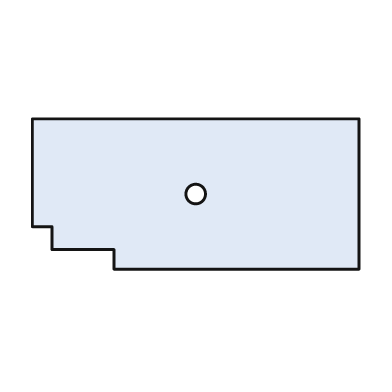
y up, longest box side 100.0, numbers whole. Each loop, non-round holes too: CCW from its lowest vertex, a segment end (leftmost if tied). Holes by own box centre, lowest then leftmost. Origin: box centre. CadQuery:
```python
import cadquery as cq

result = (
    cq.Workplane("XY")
    .moveTo(-25.0, -23.0)
    .lineTo(50.0, -23.0)
    .lineTo(50.0, 23.0)
    .lineTo(-50.0, 23.0)
    .lineTo(-50.0, -10.0)
    .lineTo(-44.0, -10.0)
    .lineTo(-44.0, -17.0)
    .lineTo(-25.0, -17.0)
    .close()
    .moveTo(0.0, 0.0)
    .circle(3.0)
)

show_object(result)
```